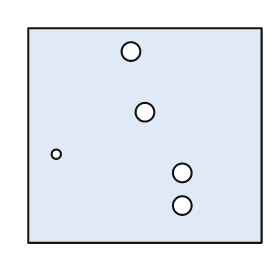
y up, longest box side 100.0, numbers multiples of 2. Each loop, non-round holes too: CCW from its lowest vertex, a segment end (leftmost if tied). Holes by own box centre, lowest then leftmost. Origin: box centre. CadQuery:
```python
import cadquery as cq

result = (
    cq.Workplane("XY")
    .moveTo(-50.0, -46.0)
    .lineTo(50.0, -46.0)
    .lineTo(50.0, 46.0)
    .lineTo(-50.0, 46.0)
    .close()
    .moveTo(16.0, -30.0)
    .circle(4.0)
    .moveTo(16.0, -16.0)
    .circle(4.0)
    .moveTo(-38.0, -8.0)
    .circle(2.0)
    .moveTo(0.0, 10.0)
    .circle(4.0)
    .moveTo(-6.0, 36.0)
    .circle(4.0)
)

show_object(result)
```